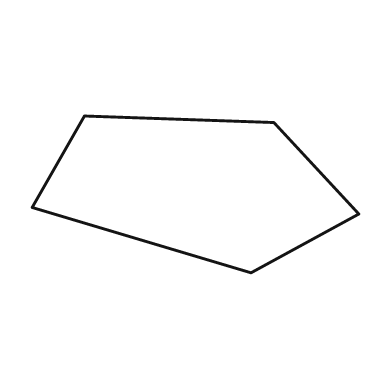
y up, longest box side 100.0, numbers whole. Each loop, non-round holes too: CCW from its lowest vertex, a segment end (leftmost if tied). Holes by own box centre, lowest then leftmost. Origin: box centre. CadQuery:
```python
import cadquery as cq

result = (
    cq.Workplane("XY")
    .moveTo(17.0, -24.0)
    .lineTo(50.0, -6.0)
    .lineTo(24.0, 22.0)
    .lineTo(-34.0, 24.0)
    .lineTo(-50.0, -4.0)
    .close()
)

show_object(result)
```